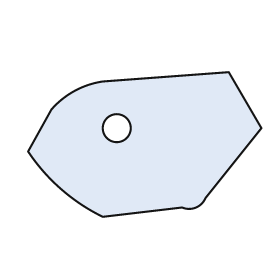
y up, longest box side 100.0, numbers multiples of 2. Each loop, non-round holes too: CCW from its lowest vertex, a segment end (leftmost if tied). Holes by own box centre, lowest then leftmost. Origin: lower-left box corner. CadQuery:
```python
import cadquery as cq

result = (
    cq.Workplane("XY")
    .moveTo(32.0, 0.0)
    .lineTo(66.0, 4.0)
    .threePointArc((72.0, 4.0), (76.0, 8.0))
    .lineTo(100.0, 38.0)
    .lineTo(86.0, 62.0)
    .lineTo(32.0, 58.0)
    .threePointArc((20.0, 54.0), (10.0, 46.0))
    .lineTo(0.0, 28.0)
    .threePointArc((14.0, 12.0), (32.0, 0.0))
    .close()
    .moveTo(38.0, 38.0)
    .circle(6.0)
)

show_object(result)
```